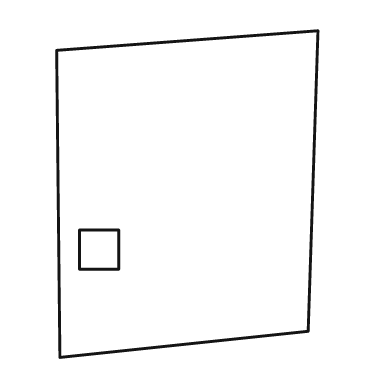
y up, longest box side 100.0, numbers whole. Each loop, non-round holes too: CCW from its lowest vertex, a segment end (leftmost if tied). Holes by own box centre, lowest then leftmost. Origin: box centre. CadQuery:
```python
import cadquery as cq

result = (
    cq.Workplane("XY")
    .moveTo(-39.0, -50.0)
    .lineTo(37.0, -42.0)
    .lineTo(40.0, 50.0)
    .lineTo(-40.0, 44.0)
    .close()
    .moveTo(-33.0, -23.0)
    .lineTo(-21.0, -23.0)
    .lineTo(-21.0, -11.0)
    .lineTo(-33.0, -11.0)
    .close()
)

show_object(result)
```